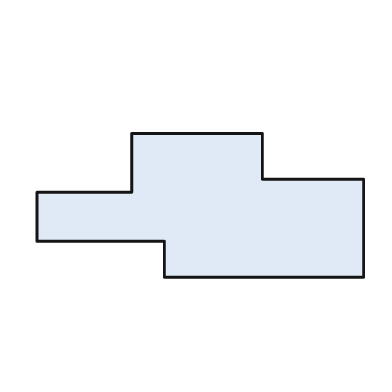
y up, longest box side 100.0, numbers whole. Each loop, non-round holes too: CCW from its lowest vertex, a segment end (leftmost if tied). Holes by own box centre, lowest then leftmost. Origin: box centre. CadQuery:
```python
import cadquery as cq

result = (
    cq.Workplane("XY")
    .moveTo(-11.0, -22.0)
    .lineTo(50.0, -22.0)
    .lineTo(50.0, 8.0)
    .lineTo(19.0, 8.0)
    .lineTo(19.0, 22.0)
    .lineTo(-21.0, 22.0)
    .lineTo(-21.0, 4.0)
    .lineTo(-50.0, 4.0)
    .lineTo(-50.0, -11.0)
    .lineTo(-11.0, -11.0)
    .close()
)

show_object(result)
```